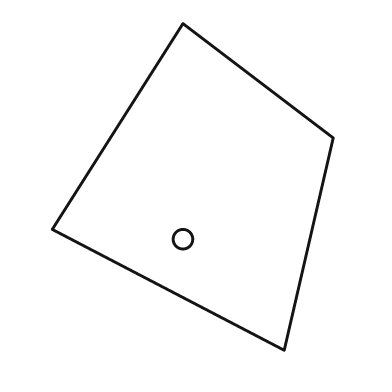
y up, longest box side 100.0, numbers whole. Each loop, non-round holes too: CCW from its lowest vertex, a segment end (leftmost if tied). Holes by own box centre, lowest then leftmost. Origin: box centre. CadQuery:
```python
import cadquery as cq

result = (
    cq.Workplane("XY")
    .moveTo(28.0, -50.0)
    .lineTo(43.0, 15.0)
    .lineTo(-3.0, 50.0)
    .lineTo(-43.0, -13.0)
    .close()
    .moveTo(-3.0, -16.0)
    .circle(3.0)
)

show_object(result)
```